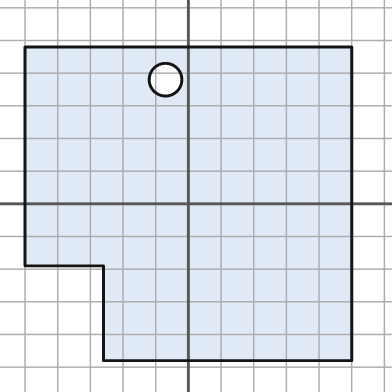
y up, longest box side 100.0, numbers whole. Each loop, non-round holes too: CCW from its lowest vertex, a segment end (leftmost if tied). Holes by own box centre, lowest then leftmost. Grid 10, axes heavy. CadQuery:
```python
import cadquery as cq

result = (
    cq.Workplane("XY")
    .moveTo(-26.0, -48.0)
    .lineTo(50.0, -48.0)
    .lineTo(50.0, 48.0)
    .lineTo(-50.0, 48.0)
    .lineTo(-50.0, -19.0)
    .lineTo(-26.0, -19.0)
    .close()
    .moveTo(-7.0, 38.0)
    .circle(5.0)
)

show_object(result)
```